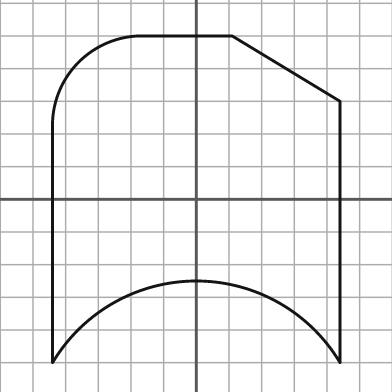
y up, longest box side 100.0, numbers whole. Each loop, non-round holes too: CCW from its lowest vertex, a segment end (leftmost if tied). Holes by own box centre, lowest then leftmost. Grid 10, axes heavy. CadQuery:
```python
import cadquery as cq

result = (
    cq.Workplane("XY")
    .moveTo(-44.0, -50.0)
    .threePointArc((0.0, -25.0), (44.0, -50.0))
    .lineTo(44.0, 30.0)
    .lineTo(11.0, 50.0)
    .lineTo(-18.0, 50.0)
    .threePointArc((-36.0, 42.0), (-44.0, 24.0))
    .close()
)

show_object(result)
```